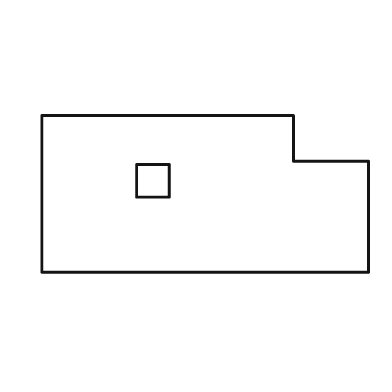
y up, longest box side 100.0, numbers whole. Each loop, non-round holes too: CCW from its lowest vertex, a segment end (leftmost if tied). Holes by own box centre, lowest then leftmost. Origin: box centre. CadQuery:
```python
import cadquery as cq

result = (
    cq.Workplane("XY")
    .moveTo(-50.0, -24.0)
    .lineTo(50.0, -24.0)
    .lineTo(50.0, 10.0)
    .lineTo(27.0, 10.0)
    .lineTo(27.0, 24.0)
    .lineTo(-50.0, 24.0)
    .close()
    .moveTo(-21.0, -1.0)
    .lineTo(-11.0, -1.0)
    .lineTo(-11.0, 9.0)
    .lineTo(-21.0, 9.0)
    .close()
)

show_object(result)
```